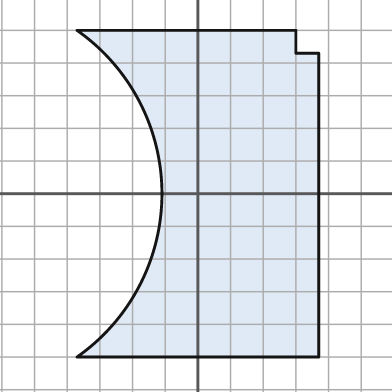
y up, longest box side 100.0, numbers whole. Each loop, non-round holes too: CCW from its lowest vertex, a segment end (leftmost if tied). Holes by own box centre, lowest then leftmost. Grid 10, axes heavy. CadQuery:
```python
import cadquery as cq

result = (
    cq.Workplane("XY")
    .moveTo(-37.0, -50.0)
    .lineTo(37.0, -50.0)
    .lineTo(37.0, 43.0)
    .lineTo(30.0, 43.0)
    .lineTo(30.0, 50.0)
    .lineTo(-37.0, 50.0)
    .threePointArc((-11.0, 0.0), (-37.0, -50.0))
    .close()
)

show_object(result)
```